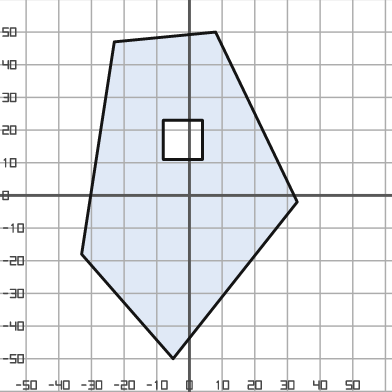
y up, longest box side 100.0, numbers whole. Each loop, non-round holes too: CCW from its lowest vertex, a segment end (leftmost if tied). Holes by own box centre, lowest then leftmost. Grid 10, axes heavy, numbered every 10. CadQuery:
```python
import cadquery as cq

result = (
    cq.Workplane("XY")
    .moveTo(-5.0, -50.0)
    .lineTo(33.0, -2.0)
    .lineTo(8.0, 50.0)
    .lineTo(-23.0, 47.0)
    .lineTo(-33.0, -18.0)
    .close()
    .moveTo(-8.0, 11.0)
    .lineTo(4.0, 11.0)
    .lineTo(4.0, 23.0)
    .lineTo(-8.0, 23.0)
    .close()
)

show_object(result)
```